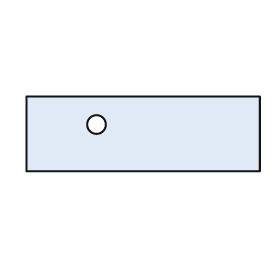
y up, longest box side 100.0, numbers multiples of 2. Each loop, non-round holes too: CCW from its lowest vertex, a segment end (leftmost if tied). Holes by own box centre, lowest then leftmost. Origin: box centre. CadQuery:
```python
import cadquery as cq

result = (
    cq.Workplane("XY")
    .moveTo(-50.0, -16.0)
    .lineTo(50.0, -16.0)
    .lineTo(50.0, 16.0)
    .lineTo(-50.0, 16.0)
    .close()
    .moveTo(-20.0, 4.0)
    .circle(4.0)
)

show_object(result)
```